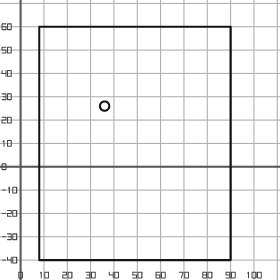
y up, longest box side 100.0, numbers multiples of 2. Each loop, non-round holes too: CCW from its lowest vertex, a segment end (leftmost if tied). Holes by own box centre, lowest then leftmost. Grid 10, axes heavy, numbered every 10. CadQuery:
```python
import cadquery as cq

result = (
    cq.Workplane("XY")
    .moveTo(8.0, -40.0)
    .lineTo(90.0, -40.0)
    .lineTo(90.0, 60.0)
    .lineTo(8.0, 60.0)
    .close()
    .moveTo(36.0, 26.0)
    .circle(2.0)
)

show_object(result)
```